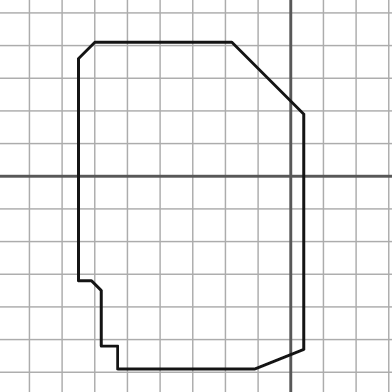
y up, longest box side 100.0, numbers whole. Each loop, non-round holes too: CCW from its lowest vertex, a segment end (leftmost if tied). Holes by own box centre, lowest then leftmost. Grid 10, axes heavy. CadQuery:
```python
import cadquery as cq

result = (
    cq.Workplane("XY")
    .moveTo(-53.0, -59.0)
    .lineTo(-11.0, -59.0)
    .lineTo(4.0, -53.0)
    .lineTo(4.0, 19.0)
    .lineTo(-18.0, 41.0)
    .lineTo(-60.0, 41.0)
    .lineTo(-65.0, 36.0)
    .lineTo(-65.0, -32.0)
    .lineTo(-61.0, -32.0)
    .lineTo(-58.0, -35.0)
    .lineTo(-58.0, -52.0)
    .lineTo(-53.0, -52.0)
    .close()
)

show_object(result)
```